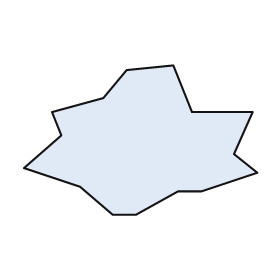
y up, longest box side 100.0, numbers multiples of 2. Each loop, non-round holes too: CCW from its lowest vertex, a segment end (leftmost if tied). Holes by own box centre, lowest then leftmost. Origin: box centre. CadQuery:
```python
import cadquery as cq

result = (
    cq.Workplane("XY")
    .moveTo(-12.0, -32.0)
    .lineTo(-2.0, -32.0)
    .lineTo(16.0, -22.0)
    .lineTo(26.0, -22.0)
    .lineTo(50.0, -14.0)
    .lineTo(40.0, -6.0)
    .lineTo(48.0, 12.0)
    .lineTo(22.0, 12.0)
    .lineTo(14.0, 32.0)
    .lineTo(-6.0, 30.0)
    .lineTo(-16.0, 18.0)
    .lineTo(-38.0, 12.0)
    .lineTo(-34.0, 2.0)
    .lineTo(-50.0, -12.0)
    .lineTo(-26.0, -20.0)
    .close()
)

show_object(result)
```